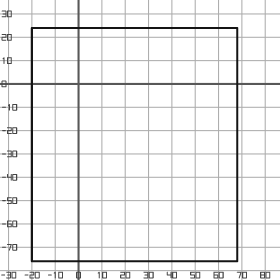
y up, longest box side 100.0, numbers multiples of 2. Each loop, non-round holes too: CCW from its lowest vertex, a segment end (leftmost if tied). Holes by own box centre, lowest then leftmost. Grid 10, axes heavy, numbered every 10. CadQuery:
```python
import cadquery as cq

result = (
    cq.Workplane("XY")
    .moveTo(-20.0, -76.0)
    .lineTo(68.0, -76.0)
    .lineTo(68.0, 24.0)
    .lineTo(-20.0, 24.0)
    .close()
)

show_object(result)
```